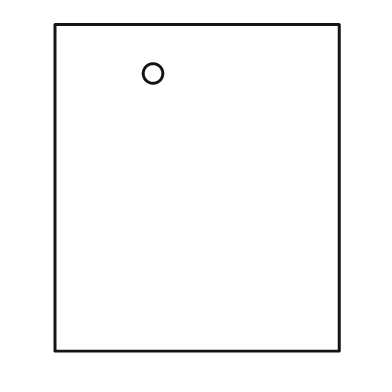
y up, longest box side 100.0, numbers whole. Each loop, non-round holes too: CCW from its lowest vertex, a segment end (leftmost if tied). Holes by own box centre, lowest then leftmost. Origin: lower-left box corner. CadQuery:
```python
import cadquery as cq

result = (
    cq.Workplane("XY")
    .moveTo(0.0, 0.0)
    .lineTo(87.0, 0.0)
    .lineTo(87.0, 100.0)
    .lineTo(0.0, 100.0)
    .close()
    .moveTo(30.0, 85.0)
    .circle(3.0)
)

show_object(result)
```